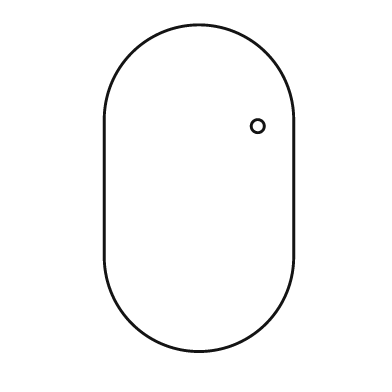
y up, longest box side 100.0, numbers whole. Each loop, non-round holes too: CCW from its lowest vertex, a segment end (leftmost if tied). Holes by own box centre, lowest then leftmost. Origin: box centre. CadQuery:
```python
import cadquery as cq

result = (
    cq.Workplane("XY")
    .moveTo(-29.0, -21.0)
    .threePointArc((0.0, -50.0), (29.0, -21.0))
    .lineTo(29.0, 21.0)
    .threePointArc((0.0, 50.0), (-29.0, 21.0))
    .close()
    .moveTo(18.0, 19.0)
    .circle(2.0)
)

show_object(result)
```